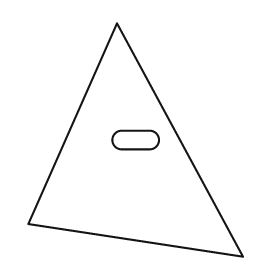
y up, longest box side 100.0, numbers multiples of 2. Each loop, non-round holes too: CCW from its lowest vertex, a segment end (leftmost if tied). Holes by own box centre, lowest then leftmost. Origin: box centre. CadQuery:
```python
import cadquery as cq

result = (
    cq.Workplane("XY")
    .moveTo(46.0, -50.0)
    .lineTo(-8.0, 50.0)
    .lineTo(-46.0, -36.0)
    .close()
    .moveTo(-6.0, -4.0)
    .lineTo(6.0, -4.0)
    .threePointArc((10.0, 0.0), (6.0, 4.0))
    .lineTo(-6.0, 4.0)
    .threePointArc((-10.0, 0.0), (-6.0, -4.0))
    .close()
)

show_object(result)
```